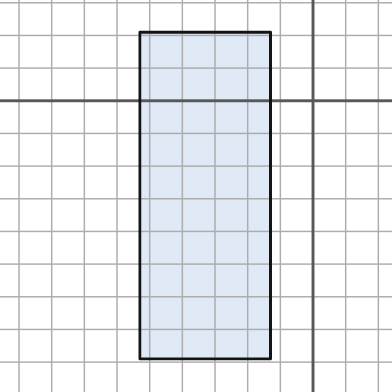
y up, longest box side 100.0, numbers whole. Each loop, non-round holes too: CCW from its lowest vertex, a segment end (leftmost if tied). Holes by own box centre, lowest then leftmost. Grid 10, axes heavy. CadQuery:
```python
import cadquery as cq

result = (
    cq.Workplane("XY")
    .moveTo(-53.0, -79.0)
    .lineTo(-13.0, -79.0)
    .lineTo(-13.0, 21.0)
    .lineTo(-53.0, 21.0)
    .close()
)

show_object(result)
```